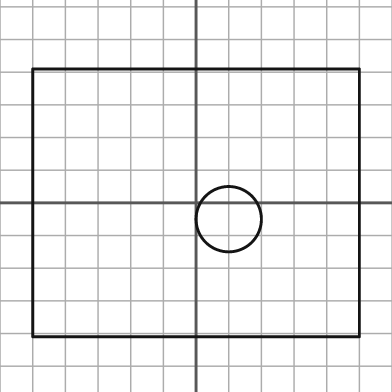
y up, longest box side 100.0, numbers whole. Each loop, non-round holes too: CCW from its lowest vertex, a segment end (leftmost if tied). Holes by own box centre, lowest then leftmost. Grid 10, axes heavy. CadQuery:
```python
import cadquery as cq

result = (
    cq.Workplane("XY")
    .moveTo(-50.0, -41.0)
    .lineTo(50.0, -41.0)
    .lineTo(50.0, 41.0)
    .lineTo(-50.0, 41.0)
    .close()
    .moveTo(10.0, -5.0)
    .circle(10.0)
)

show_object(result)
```